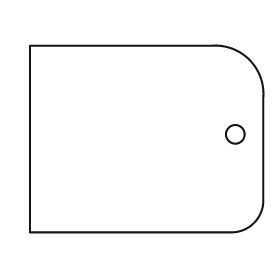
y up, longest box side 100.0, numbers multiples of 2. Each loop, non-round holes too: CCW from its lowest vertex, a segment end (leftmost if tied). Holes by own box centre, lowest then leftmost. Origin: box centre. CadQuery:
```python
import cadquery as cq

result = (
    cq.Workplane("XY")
    .moveTo(-50.0, -40.0)
    .lineTo(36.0, -40.0)
    .threePointArc((46.0, -36.0), (50.0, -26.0))
    .lineTo(50.0, 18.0)
    .threePointArc((44.0, 34.0), (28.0, 40.0))
    .lineTo(-50.0, 40.0)
    .close()
    .moveTo(38.0, 2.0)
    .circle(4.0)
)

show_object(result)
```